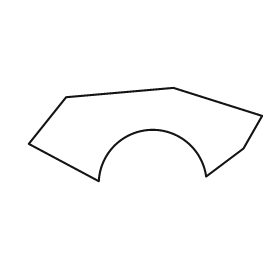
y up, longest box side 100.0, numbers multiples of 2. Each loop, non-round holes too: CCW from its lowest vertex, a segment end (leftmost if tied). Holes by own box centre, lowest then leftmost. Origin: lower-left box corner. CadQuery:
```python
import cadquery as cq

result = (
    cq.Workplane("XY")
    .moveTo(30.0, 0.0)
    .threePointArc((52.0, 22.0), (76.0, 2.0))
    .lineTo(92.0, 14.0)
    .lineTo(100.0, 28.0)
    .lineTo(62.0, 40.0)
    .lineTo(16.0, 36.0)
    .lineTo(0.0, 16.0)
    .close()
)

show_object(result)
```